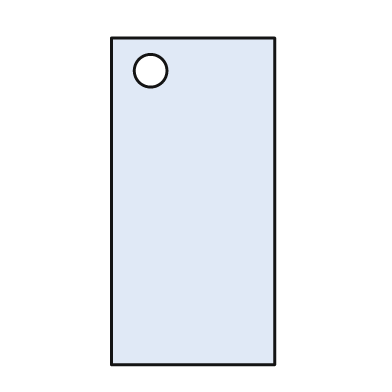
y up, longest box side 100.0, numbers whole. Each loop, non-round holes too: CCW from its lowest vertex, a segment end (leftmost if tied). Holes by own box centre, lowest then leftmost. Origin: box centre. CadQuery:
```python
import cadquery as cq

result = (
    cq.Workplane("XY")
    .moveTo(-25.0, -50.0)
    .lineTo(25.0, -50.0)
    .lineTo(25.0, 50.0)
    .lineTo(-25.0, 50.0)
    .close()
    .moveTo(-13.0, 40.0)
    .circle(5.0)
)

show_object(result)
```